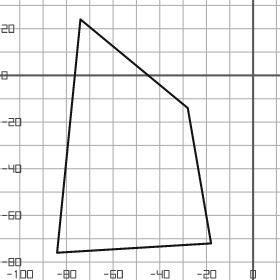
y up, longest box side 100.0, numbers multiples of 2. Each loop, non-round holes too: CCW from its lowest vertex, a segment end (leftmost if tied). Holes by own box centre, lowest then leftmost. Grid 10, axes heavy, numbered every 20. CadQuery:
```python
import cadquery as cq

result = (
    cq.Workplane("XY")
    .moveTo(-84.0, -76.0)
    .lineTo(-18.0, -72.0)
    .lineTo(-28.0, -14.0)
    .lineTo(-74.0, 24.0)
    .close()
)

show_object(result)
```